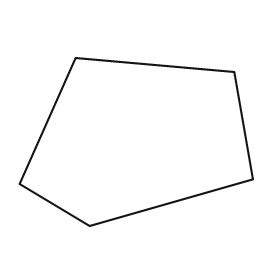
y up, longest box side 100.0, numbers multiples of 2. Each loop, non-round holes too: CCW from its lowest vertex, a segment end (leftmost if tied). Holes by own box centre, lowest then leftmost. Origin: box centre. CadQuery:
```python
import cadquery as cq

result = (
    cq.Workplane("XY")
    .moveTo(-20.0, -36.0)
    .lineTo(50.0, -16.0)
    .lineTo(42.0, 30.0)
    .lineTo(-26.0, 36.0)
    .lineTo(-50.0, -18.0)
    .close()
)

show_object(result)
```